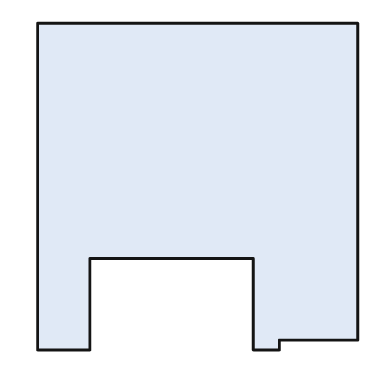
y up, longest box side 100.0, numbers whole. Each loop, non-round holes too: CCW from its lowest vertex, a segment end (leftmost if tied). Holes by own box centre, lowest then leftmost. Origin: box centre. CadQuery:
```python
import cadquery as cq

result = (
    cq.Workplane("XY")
    .moveTo(-49.0, -50.0)
    .lineTo(-33.0, -50.0)
    .lineTo(-33.0, -22.0)
    .lineTo(17.0, -22.0)
    .lineTo(17.0, -50.0)
    .lineTo(25.0, -50.0)
    .lineTo(25.0, -47.0)
    .lineTo(49.0, -47.0)
    .lineTo(49.0, 50.0)
    .lineTo(-49.0, 50.0)
    .close()
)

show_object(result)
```